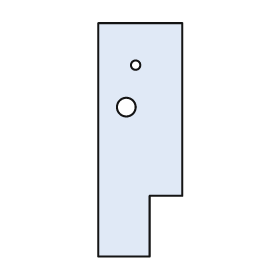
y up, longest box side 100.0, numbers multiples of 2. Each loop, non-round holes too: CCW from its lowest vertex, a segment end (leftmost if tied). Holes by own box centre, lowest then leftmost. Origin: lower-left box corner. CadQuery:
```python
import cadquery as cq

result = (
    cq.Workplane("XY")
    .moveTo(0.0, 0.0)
    .lineTo(22.0, 0.0)
    .lineTo(22.0, 26.0)
    .lineTo(36.0, 26.0)
    .lineTo(36.0, 100.0)
    .lineTo(0.0, 100.0)
    .close()
    .moveTo(12.0, 64.0)
    .circle(4.0)
    .moveTo(16.0, 82.0)
    .circle(2.0)
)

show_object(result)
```